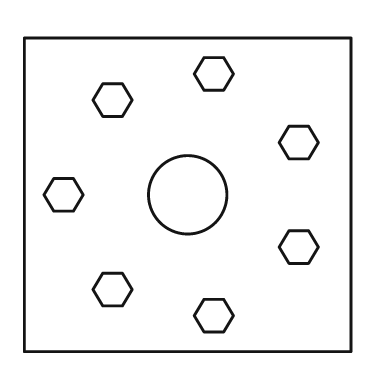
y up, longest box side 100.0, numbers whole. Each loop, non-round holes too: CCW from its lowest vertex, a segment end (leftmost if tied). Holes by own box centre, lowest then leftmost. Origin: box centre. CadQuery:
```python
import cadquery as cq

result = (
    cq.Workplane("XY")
    .moveTo(-50.0, -48.0)
    .lineTo(50.0, -48.0)
    .lineTo(50.0, 48.0)
    .lineTo(-50.0, 48.0)
    .close()
    .moveTo(5.0, -42.0)
    .lineTo(11.0, -42.0)
    .lineTo(14.0, -37.0)
    .lineTo(11.0, -32.0)
    .lineTo(5.0, -32.0)
    .lineTo(2.0, -37.0)
    .close()
    .moveTo(-26.0, -34.0)
    .lineTo(-20.0, -34.0)
    .lineTo(-17.0, -29.0)
    .lineTo(-20.0, -24.0)
    .lineTo(-26.0, -24.0)
    .lineTo(-29.0, -29.0)
    .close()
    .moveTo(31.0, -21.0)
    .lineTo(37.0, -21.0)
    .lineTo(40.0, -16.0)
    .lineTo(37.0, -11.0)
    .lineTo(31.0, -11.0)
    .lineTo(28.0, -16.0)
    .close()
    .moveTo(-41.0, -5.0)
    .lineTo(-35.0, -5.0)
    .lineTo(-32.0, 0.0)
    .lineTo(-35.0, 5.0)
    .lineTo(-41.0, 5.0)
    .lineTo(-44.0, 0.0)
    .close()
    .moveTo(0.0, 0.0)
    .circle(12.0)
    .moveTo(31.0, 11.0)
    .lineTo(37.0, 11.0)
    .lineTo(40.0, 16.0)
    .lineTo(37.0, 21.0)
    .lineTo(31.0, 21.0)
    .lineTo(28.0, 16.0)
    .close()
    .moveTo(-26.0, 24.0)
    .lineTo(-20.0, 24.0)
    .lineTo(-17.0, 29.0)
    .lineTo(-20.0, 34.0)
    .lineTo(-26.0, 34.0)
    .lineTo(-29.0, 29.0)
    .close()
    .moveTo(5.0, 32.0)
    .lineTo(11.0, 32.0)
    .lineTo(14.0, 37.0)
    .lineTo(11.0, 42.0)
    .lineTo(5.0, 42.0)
    .lineTo(2.0, 37.0)
    .close()
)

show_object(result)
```